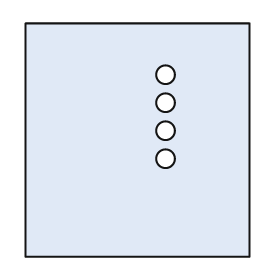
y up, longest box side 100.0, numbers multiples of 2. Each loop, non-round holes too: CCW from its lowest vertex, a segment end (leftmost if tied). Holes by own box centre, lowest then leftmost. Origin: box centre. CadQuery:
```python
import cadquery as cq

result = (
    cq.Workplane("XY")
    .moveTo(-48.0, -50.0)
    .lineTo(48.0, -50.0)
    .lineTo(48.0, 50.0)
    .lineTo(-48.0, 50.0)
    .close()
    .moveTo(12.0, -8.0)
    .circle(4.0)
    .moveTo(12.0, 4.0)
    .circle(4.0)
    .moveTo(12.0, 16.0)
    .circle(4.0)
    .moveTo(12.0, 28.0)
    .circle(4.0)
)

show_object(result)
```